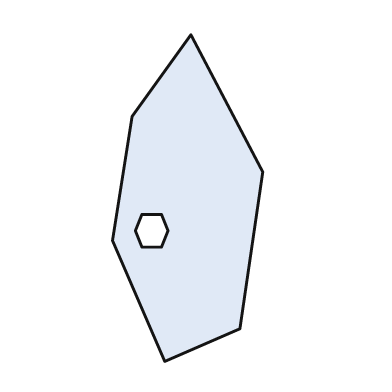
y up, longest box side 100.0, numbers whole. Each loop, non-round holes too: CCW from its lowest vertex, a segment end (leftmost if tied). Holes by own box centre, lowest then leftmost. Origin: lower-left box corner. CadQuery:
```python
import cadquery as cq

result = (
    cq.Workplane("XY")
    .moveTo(16.0, 0.0)
    .lineTo(39.0, 10.0)
    .lineTo(46.0, 58.0)
    .lineTo(24.0, 100.0)
    .lineTo(6.0, 75.0)
    .lineTo(0.0, 37.0)
    .close()
    .moveTo(9.0, 35.0)
    .lineTo(15.0, 35.0)
    .lineTo(17.0, 40.0)
    .lineTo(15.0, 45.0)
    .lineTo(9.0, 45.0)
    .lineTo(7.0, 40.0)
    .close()
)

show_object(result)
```